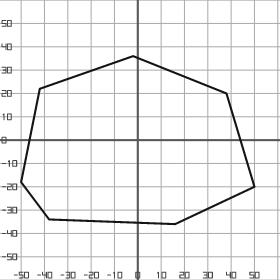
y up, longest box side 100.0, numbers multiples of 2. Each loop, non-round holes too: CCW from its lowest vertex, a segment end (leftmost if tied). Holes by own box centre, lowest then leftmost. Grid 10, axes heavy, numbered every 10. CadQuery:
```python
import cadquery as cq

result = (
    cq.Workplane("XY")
    .moveTo(16.0, -36.0)
    .lineTo(50.0, -20.0)
    .lineTo(38.0, 20.0)
    .lineTo(-2.0, 36.0)
    .lineTo(-42.0, 22.0)
    .lineTo(-50.0, -18.0)
    .lineTo(-38.0, -34.0)
    .close()
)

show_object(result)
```